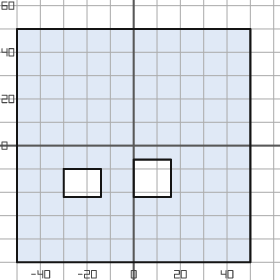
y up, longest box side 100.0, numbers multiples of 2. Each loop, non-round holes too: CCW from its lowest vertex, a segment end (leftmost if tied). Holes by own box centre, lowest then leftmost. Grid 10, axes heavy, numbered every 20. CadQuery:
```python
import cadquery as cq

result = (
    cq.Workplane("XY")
    .moveTo(-50.0, -50.0)
    .lineTo(50.0, -50.0)
    .lineTo(50.0, 50.0)
    .lineTo(-50.0, 50.0)
    .close()
    .moveTo(-30.0, -22.0)
    .lineTo(-14.0, -22.0)
    .lineTo(-14.0, -10.0)
    .lineTo(-30.0, -10.0)
    .close()
    .moveTo(0.0, -22.0)
    .lineTo(16.0, -22.0)
    .lineTo(16.0, -6.0)
    .lineTo(0.0, -6.0)
    .close()
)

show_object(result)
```